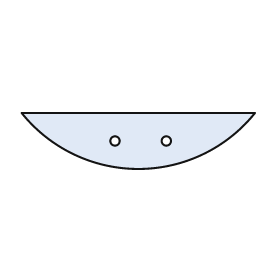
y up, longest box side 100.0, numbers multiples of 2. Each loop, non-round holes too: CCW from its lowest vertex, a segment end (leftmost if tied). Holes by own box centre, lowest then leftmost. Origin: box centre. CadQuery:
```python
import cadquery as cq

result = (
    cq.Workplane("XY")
    .moveTo(-50.0, 12.0)
    .threePointArc((0.0, -12.0), (50.0, 12.0))
    .close()
    .moveTo(-10.0, 0.0)
    .circle(2.0)
    .moveTo(12.0, 0.0)
    .circle(2.0)
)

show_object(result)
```